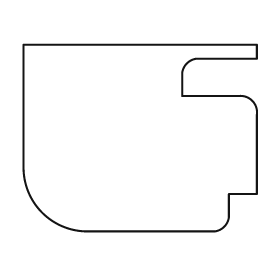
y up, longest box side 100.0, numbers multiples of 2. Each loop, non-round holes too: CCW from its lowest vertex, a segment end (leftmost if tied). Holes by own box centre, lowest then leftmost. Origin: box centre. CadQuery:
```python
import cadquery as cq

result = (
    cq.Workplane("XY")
    .moveTo(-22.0, -40.0)
    .lineTo(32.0, -40.0)
    .threePointArc((36.0, -38.0), (38.0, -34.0))
    .lineTo(38.0, -24.0)
    .lineTo(50.0, -24.0)
    .lineTo(50.0, 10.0)
    .threePointArc((48.0, 16.0), (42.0, 18.0))
    .lineTo(18.0, 18.0)
    .lineTo(18.0, 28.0)
    .threePointArc((20.0, 32.0), (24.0, 34.0))
    .lineTo(50.0, 34.0)
    .lineTo(50.0, 40.0)
    .lineTo(-50.0, 40.0)
    .lineTo(-50.0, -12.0)
    .threePointArc((-42.0, -32.0), (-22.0, -40.0))
    .close()
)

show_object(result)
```